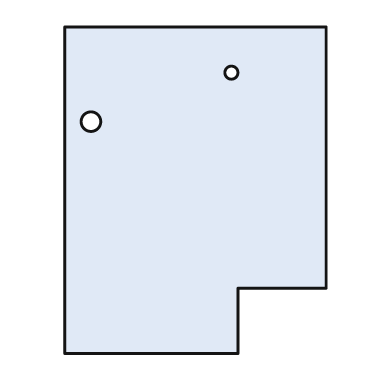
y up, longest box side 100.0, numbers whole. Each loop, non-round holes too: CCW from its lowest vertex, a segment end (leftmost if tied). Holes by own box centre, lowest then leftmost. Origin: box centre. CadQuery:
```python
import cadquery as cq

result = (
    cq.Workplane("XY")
    .moveTo(-40.0, -50.0)
    .lineTo(13.0, -50.0)
    .lineTo(13.0, -30.0)
    .lineTo(40.0, -30.0)
    .lineTo(40.0, 50.0)
    .lineTo(-40.0, 50.0)
    .close()
    .moveTo(-32.0, 21.0)
    .circle(3.0)
    .moveTo(11.0, 36.0)
    .circle(2.0)
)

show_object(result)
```